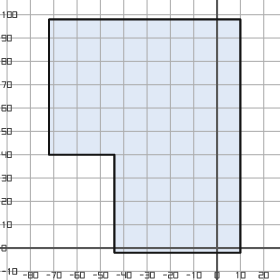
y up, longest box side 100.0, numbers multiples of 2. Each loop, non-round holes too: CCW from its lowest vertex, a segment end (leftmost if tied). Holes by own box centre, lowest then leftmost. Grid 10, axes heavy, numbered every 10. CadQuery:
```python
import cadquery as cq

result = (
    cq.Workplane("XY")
    .moveTo(-44.0, -2.0)
    .lineTo(10.0, -2.0)
    .lineTo(10.0, 98.0)
    .lineTo(-72.0, 98.0)
    .lineTo(-72.0, 40.0)
    .lineTo(-44.0, 40.0)
    .close()
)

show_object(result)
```